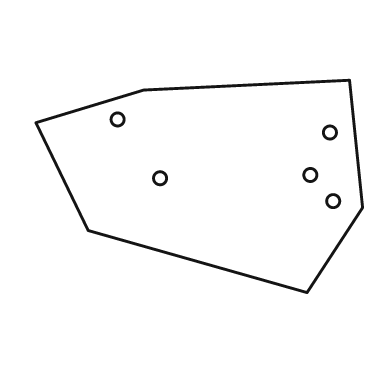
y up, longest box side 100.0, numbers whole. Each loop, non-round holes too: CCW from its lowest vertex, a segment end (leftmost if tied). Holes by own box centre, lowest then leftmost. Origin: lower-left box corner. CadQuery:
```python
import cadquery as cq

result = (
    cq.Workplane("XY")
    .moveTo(83.0, 0.0)
    .lineTo(100.0, 26.0)
    .lineTo(96.0, 65.0)
    .lineTo(33.0, 62.0)
    .lineTo(0.0, 52.0)
    .lineTo(16.0, 19.0)
    .close()
    .moveTo(91.0, 28.0)
    .circle(2.0)
    .moveTo(38.0, 35.0)
    .circle(2.0)
    .moveTo(84.0, 36.0)
    .circle(2.0)
    .moveTo(90.0, 49.0)
    .circle(2.0)
    .moveTo(25.0, 53.0)
    .circle(2.0)
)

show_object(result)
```